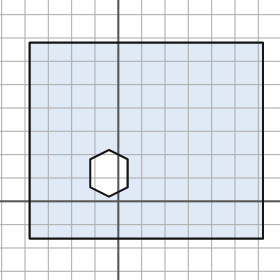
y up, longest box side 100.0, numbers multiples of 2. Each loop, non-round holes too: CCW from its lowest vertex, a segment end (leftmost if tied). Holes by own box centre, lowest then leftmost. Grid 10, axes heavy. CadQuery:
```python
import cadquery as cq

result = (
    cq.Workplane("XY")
    .moveTo(-38.0, -16.0)
    .lineTo(62.0, -16.0)
    .lineTo(62.0, 68.0)
    .lineTo(-38.0, 68.0)
    .close()
    .moveTo(-4.0, 2.0)
    .lineTo(4.0, 6.0)
    .lineTo(4.0, 18.0)
    .lineTo(-4.0, 22.0)
    .lineTo(-12.0, 18.0)
    .lineTo(-12.0, 6.0)
    .close()
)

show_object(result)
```